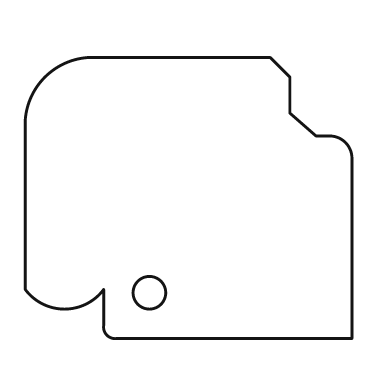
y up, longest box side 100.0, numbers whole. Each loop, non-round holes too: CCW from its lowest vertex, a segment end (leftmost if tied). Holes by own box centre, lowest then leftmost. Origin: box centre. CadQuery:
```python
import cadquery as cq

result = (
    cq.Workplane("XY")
    .moveTo(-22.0, -43.0)
    .lineTo(50.0, -43.0)
    .lineTo(50.0, 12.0)
    .threePointArc((48.0, 17.0), (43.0, 19.0))
    .lineTo(39.0, 19.0)
    .lineTo(31.0, 26.0)
    .lineTo(31.0, 37.0)
    .lineTo(25.0, 43.0)
    .lineTo(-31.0, 43.0)
    .threePointArc((-44.0, 37.0), (-50.0, 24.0))
    .lineTo(-50.0, -28.0)
    .threePointArc((-38.0, -34.0), (-26.0, -28.0))
    .lineTo(-26.0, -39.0)
    .threePointArc((-25.0, -42.0), (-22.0, -43.0))
    .close()
    .moveTo(-12.0, -29.0)
    .circle(5.0)
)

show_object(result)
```